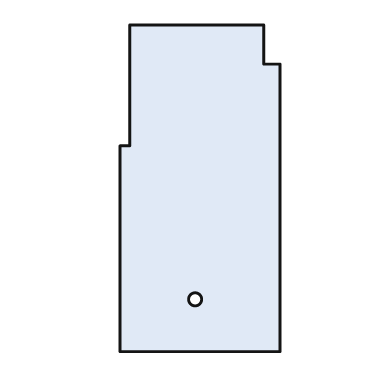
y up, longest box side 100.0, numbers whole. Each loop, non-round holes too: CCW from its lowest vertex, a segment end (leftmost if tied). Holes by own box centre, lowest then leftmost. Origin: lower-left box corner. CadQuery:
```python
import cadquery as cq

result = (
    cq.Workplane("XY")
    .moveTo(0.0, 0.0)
    .lineTo(49.0, 0.0)
    .lineTo(49.0, 88.0)
    .lineTo(44.0, 88.0)
    .lineTo(44.0, 100.0)
    .lineTo(3.0, 100.0)
    .lineTo(3.0, 63.0)
    .lineTo(0.0, 63.0)
    .close()
    .moveTo(23.0, 16.0)
    .circle(2.0)
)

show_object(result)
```